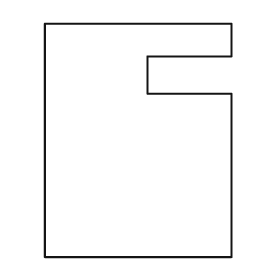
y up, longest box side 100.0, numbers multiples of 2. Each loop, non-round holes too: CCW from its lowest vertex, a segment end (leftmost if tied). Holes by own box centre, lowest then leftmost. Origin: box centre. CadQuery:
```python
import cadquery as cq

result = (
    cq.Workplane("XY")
    .moveTo(-40.0, -50.0)
    .lineTo(40.0, -50.0)
    .lineTo(40.0, 20.0)
    .lineTo(4.0, 20.0)
    .lineTo(4.0, 36.0)
    .lineTo(40.0, 36.0)
    .lineTo(40.0, 50.0)
    .lineTo(-40.0, 50.0)
    .close()
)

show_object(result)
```